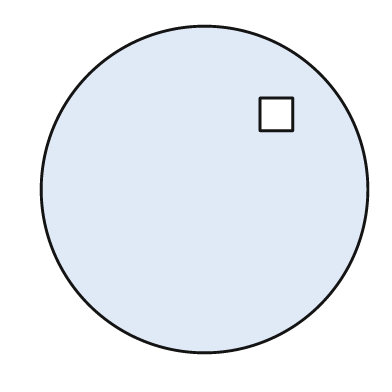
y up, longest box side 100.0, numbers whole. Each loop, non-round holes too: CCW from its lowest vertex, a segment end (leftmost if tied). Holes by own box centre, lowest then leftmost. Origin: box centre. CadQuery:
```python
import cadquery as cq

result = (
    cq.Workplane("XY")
    .moveTo(0.0, 0.0)
    .circle(50.0)
    .moveTo(17.0, 18.0)
    .lineTo(27.0, 18.0)
    .lineTo(27.0, 28.0)
    .lineTo(17.0, 28.0)
    .close()
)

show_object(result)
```